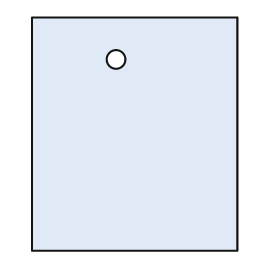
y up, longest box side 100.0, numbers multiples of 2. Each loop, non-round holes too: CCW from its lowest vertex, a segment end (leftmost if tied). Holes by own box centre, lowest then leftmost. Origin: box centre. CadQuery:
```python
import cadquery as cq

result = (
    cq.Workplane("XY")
    .moveTo(-44.0, -50.0)
    .lineTo(44.0, -50.0)
    .lineTo(44.0, 50.0)
    .lineTo(-44.0, 50.0)
    .close()
    .moveTo(-8.0, 32.0)
    .circle(4.0)
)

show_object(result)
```